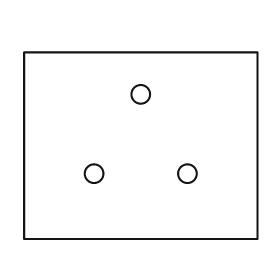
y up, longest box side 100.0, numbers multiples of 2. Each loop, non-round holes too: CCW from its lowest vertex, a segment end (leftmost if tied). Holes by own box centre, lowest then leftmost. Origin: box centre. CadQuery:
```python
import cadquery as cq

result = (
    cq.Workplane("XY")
    .moveTo(-50.0, -40.0)
    .lineTo(50.0, -40.0)
    .lineTo(50.0, 40.0)
    .lineTo(-50.0, 40.0)
    .close()
    .moveTo(-20.0, -12.0)
    .circle(4.0)
    .moveTo(20.0, -12.0)
    .circle(4.0)
    .moveTo(0.0, 22.0)
    .circle(4.0)
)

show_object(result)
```